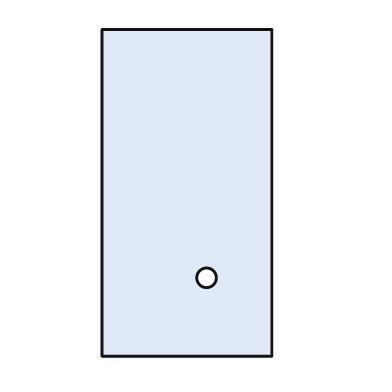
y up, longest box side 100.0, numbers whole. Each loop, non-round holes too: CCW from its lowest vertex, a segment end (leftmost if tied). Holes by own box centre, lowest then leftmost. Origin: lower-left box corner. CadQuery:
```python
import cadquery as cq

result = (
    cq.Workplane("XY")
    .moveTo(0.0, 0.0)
    .lineTo(52.0, 0.0)
    .lineTo(52.0, 100.0)
    .lineTo(0.0, 100.0)
    .close()
    .moveTo(32.0, 24.0)
    .circle(3.0)
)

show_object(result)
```